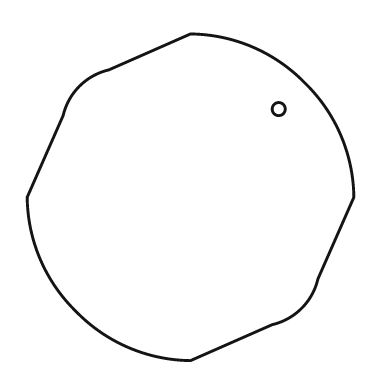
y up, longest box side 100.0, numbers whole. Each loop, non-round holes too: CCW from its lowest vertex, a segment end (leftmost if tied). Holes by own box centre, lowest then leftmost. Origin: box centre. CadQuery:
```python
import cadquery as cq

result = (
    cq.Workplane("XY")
    .moveTo(0.0, -50.0)
    .lineTo(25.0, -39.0)
    .threePointArc((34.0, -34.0), (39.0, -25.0))
    .lineTo(50.0, 0.0)
    .threePointArc((46.0, 19.0), (35.0, 35.0))
    .threePointArc((19.0, 46.0), (0.0, 50.0))
    .lineTo(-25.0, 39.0)
    .threePointArc((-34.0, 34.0), (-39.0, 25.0))
    .lineTo(-50.0, 0.0)
    .threePointArc((-46.0, -19.0), (-35.0, -35.0))
    .threePointArc((-19.0, -46.0), (0.0, -50.0))
    .close()
    .moveTo(27.0, 27.0)
    .circle(2.0)
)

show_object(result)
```